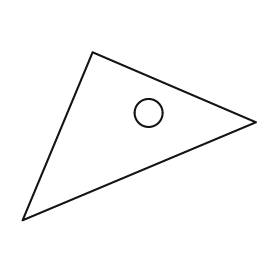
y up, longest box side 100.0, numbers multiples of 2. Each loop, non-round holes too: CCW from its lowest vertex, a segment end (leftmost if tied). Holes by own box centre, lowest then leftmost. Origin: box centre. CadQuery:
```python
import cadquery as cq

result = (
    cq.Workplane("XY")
    .moveTo(-50.0, -36.0)
    .lineTo(50.0, 6.0)
    .lineTo(-20.0, 36.0)
    .close()
    .moveTo(4.0, 10.0)
    .circle(6.0)
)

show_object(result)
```